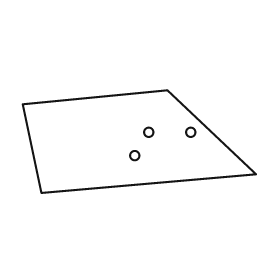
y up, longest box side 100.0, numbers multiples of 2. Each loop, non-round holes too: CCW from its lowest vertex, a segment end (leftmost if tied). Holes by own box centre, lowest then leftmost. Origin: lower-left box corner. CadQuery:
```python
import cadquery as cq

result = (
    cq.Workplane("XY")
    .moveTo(8.0, 0.0)
    .lineTo(100.0, 8.0)
    .lineTo(62.0, 44.0)
    .lineTo(0.0, 38.0)
    .close()
    .moveTo(48.0, 16.0)
    .circle(2.0)
    .moveTo(54.0, 26.0)
    .circle(2.0)
    .moveTo(72.0, 26.0)
    .circle(2.0)
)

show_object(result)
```